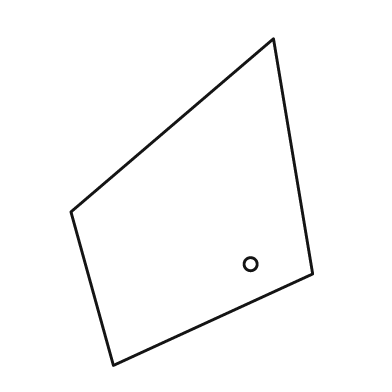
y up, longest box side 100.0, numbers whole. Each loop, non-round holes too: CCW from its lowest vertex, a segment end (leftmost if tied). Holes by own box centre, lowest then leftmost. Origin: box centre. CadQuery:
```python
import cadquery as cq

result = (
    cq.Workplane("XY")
    .moveTo(-24.0, -50.0)
    .lineTo(37.0, -22.0)
    .lineTo(25.0, 50.0)
    .lineTo(-37.0, -3.0)
    .close()
    .moveTo(18.0, -19.0)
    .circle(2.0)
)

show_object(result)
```